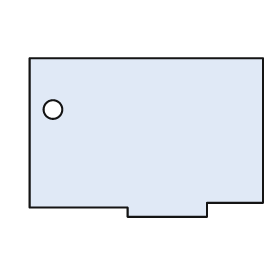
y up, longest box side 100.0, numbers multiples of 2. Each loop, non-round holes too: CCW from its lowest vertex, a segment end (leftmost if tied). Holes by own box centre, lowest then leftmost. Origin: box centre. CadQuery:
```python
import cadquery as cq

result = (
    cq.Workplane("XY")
    .moveTo(-8.0, -34.0)
    .lineTo(26.0, -34.0)
    .lineTo(26.0, -28.0)
    .lineTo(50.0, -28.0)
    .lineTo(50.0, 34.0)
    .lineTo(-50.0, 34.0)
    .lineTo(-50.0, -30.0)
    .lineTo(-8.0, -30.0)
    .close()
    .moveTo(-40.0, 12.0)
    .circle(4.0)
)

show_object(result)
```